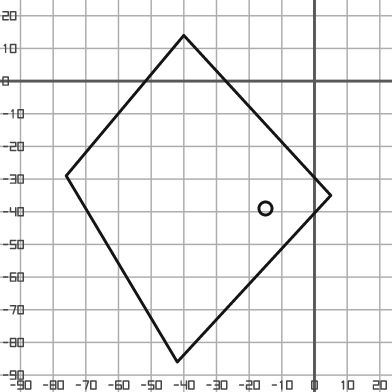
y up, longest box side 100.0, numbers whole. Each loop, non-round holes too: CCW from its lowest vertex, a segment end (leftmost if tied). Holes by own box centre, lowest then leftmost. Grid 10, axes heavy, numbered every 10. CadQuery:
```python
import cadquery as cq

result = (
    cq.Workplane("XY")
    .moveTo(-42.0, -86.0)
    .lineTo(5.0, -35.0)
    .lineTo(-40.0, 14.0)
    .lineTo(-76.0, -29.0)
    .close()
    .moveTo(-15.0, -39.0)
    .circle(2.0)
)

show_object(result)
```